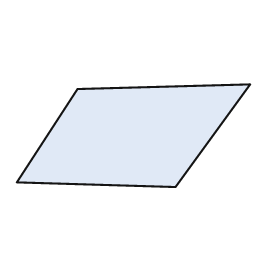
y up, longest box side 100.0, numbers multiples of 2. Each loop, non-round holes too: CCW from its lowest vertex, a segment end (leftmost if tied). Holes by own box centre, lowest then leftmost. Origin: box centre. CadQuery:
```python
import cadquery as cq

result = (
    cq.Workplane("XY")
    .moveTo(18.0, -22.0)
    .lineTo(50.0, 22.0)
    .lineTo(-24.0, 20.0)
    .lineTo(-50.0, -20.0)
    .close()
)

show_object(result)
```